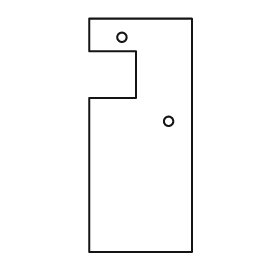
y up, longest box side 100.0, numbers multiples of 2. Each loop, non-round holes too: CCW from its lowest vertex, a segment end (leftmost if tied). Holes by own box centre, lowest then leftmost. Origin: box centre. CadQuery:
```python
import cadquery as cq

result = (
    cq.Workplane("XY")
    .moveTo(-22.0, -50.0)
    .lineTo(22.0, -50.0)
    .lineTo(22.0, 50.0)
    .lineTo(-22.0, 50.0)
    .lineTo(-22.0, 36.0)
    .lineTo(-2.0, 36.0)
    .lineTo(-2.0, 16.0)
    .lineTo(-22.0, 16.0)
    .close()
    .moveTo(12.0, 6.0)
    .circle(2.0)
    .moveTo(-8.0, 42.0)
    .circle(2.0)
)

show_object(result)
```